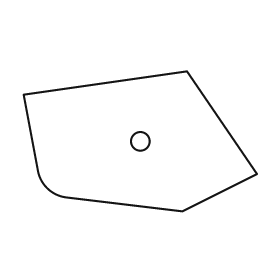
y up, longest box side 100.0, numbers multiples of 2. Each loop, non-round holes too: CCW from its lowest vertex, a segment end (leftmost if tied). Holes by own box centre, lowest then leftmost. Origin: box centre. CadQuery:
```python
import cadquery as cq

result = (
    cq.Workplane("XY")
    .moveTo(18.0, -30.0)
    .lineTo(50.0, -14.0)
    .lineTo(20.0, 30.0)
    .lineTo(-50.0, 20.0)
    .lineTo(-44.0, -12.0)
    .threePointArc((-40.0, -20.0), (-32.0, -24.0))
    .close()
    .moveTo(0.0, 0.0)
    .circle(4.0)
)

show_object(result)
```